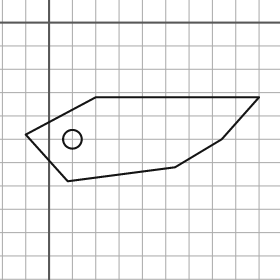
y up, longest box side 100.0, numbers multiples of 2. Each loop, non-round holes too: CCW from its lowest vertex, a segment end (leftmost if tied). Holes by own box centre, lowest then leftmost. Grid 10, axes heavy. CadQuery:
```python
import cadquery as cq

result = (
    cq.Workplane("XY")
    .moveTo(8.0, -68.0)
    .lineTo(54.0, -62.0)
    .lineTo(74.0, -50.0)
    .lineTo(90.0, -32.0)
    .lineTo(20.0, -32.0)
    .lineTo(-10.0, -48.0)
    .close()
    .moveTo(10.0, -50.0)
    .circle(4.0)
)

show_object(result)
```